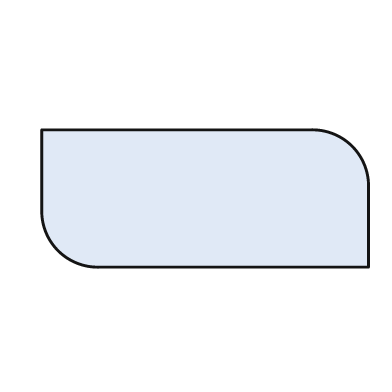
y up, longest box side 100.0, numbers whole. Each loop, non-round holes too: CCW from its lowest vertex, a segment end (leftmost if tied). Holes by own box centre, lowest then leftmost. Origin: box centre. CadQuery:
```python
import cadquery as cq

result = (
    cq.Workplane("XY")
    .moveTo(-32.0, -21.0)
    .lineTo(50.0, -21.0)
    .lineTo(50.0, 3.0)
    .threePointArc((45.0, 16.0), (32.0, 21.0))
    .lineTo(-50.0, 21.0)
    .lineTo(-50.0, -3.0)
    .threePointArc((-45.0, -16.0), (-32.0, -21.0))
    .close()
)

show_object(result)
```